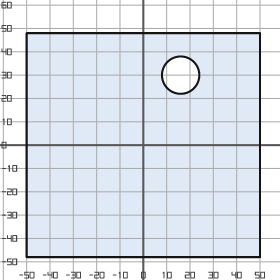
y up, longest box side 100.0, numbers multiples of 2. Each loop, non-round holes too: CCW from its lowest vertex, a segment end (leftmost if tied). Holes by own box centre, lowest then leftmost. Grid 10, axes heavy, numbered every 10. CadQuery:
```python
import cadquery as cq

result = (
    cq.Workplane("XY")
    .moveTo(-50.0, -48.0)
    .lineTo(50.0, -48.0)
    .lineTo(50.0, 48.0)
    .lineTo(-50.0, 48.0)
    .close()
    .moveTo(16.0, 30.0)
    .circle(8.0)
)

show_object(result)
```